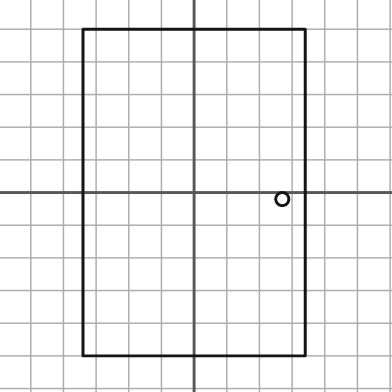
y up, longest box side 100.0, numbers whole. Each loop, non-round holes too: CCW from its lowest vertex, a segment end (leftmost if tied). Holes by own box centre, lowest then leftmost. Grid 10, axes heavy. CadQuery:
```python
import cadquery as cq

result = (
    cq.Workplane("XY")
    .moveTo(-34.0, -50.0)
    .lineTo(34.0, -50.0)
    .lineTo(34.0, 50.0)
    .lineTo(-34.0, 50.0)
    .close()
    .moveTo(27.0, -2.0)
    .circle(2.0)
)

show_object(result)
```